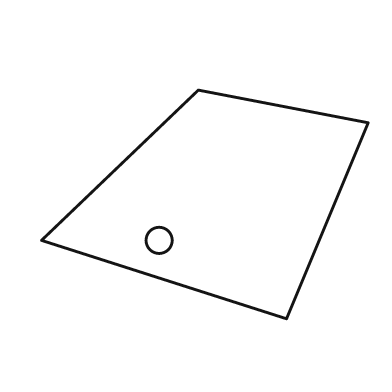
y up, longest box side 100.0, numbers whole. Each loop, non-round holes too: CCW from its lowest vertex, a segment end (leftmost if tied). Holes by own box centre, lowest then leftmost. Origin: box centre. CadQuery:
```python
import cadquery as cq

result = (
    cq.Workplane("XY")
    .moveTo(25.0, -35.0)
    .lineTo(50.0, 25.0)
    .lineTo(-2.0, 35.0)
    .lineTo(-50.0, -11.0)
    .close()
    .moveTo(-14.0, -11.0)
    .circle(4.0)
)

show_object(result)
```